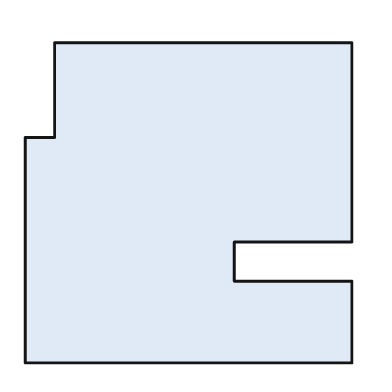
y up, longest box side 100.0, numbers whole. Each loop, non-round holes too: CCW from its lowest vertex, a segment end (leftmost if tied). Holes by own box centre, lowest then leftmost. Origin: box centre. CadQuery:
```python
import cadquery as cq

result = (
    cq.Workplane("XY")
    .moveTo(-50.0, -49.0)
    .lineTo(50.0, -49.0)
    .lineTo(50.0, -24.0)
    .lineTo(14.0, -24.0)
    .lineTo(14.0, -12.0)
    .lineTo(50.0, -12.0)
    .lineTo(50.0, 49.0)
    .lineTo(-41.0, 49.0)
    .lineTo(-41.0, 20.0)
    .lineTo(-50.0, 20.0)
    .close()
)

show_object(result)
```